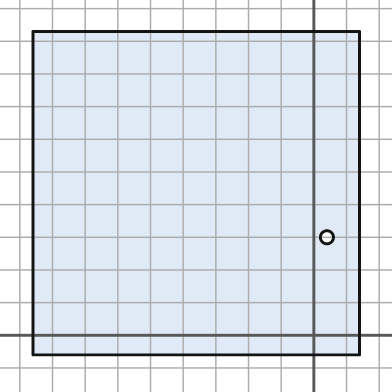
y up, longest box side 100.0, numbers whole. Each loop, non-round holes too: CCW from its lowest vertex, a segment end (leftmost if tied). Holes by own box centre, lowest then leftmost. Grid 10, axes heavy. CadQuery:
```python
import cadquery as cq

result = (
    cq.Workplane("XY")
    .moveTo(-86.0, -6.0)
    .lineTo(14.0, -6.0)
    .lineTo(14.0, 93.0)
    .lineTo(-86.0, 93.0)
    .close()
    .moveTo(4.0, 30.0)
    .circle(2.0)
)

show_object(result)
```